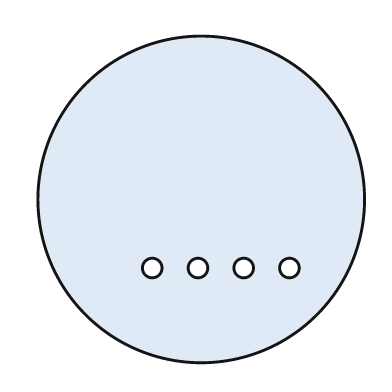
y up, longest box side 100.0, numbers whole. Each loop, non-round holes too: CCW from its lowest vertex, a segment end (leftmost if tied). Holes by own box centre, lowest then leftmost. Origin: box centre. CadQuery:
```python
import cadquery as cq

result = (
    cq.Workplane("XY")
    .moveTo(0.0, 0.0)
    .circle(50.0)
    .moveTo(-15.0, -21.0)
    .circle(3.0)
    .moveTo(-1.0, -21.0)
    .circle(3.0)
    .moveTo(13.0, -21.0)
    .circle(3.0)
    .moveTo(27.0, -21.0)
    .circle(3.0)
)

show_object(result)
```